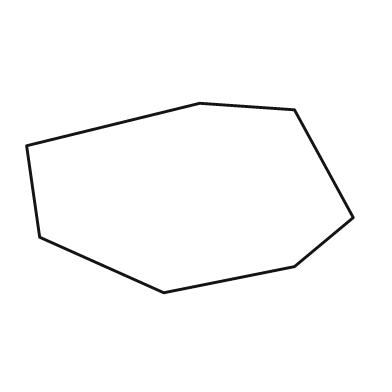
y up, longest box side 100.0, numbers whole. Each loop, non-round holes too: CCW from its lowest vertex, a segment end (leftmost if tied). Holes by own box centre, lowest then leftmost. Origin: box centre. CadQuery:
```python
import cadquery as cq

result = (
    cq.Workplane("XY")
    .moveTo(-8.0, -29.0)
    .lineTo(32.0, -21.0)
    .lineTo(50.0, -6.0)
    .lineTo(32.0, 27.0)
    .lineTo(3.0, 29.0)
    .lineTo(-50.0, 16.0)
    .lineTo(-46.0, -12.0)
    .close()
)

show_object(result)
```